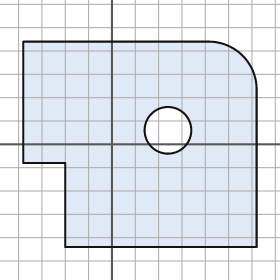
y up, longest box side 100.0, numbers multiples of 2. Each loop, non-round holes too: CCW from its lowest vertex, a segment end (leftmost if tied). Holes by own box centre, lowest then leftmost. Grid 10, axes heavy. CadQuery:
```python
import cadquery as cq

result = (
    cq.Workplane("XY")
    .moveTo(-20.0, -44.0)
    .lineTo(62.0, -44.0)
    .lineTo(62.0, 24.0)
    .threePointArc((56.0, 38.0), (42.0, 44.0))
    .lineTo(-38.0, 44.0)
    .lineTo(-38.0, -8.0)
    .lineTo(-20.0, -8.0)
    .close()
    .moveTo(24.0, 6.0)
    .circle(10.0)
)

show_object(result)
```